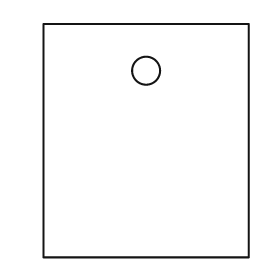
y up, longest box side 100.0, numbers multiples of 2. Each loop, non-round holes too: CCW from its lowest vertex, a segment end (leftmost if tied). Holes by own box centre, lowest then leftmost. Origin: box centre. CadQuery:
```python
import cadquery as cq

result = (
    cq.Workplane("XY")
    .moveTo(-44.0, -50.0)
    .lineTo(44.0, -50.0)
    .lineTo(44.0, 50.0)
    .lineTo(-44.0, 50.0)
    .close()
    .moveTo(0.0, 30.0)
    .circle(6.0)
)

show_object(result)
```